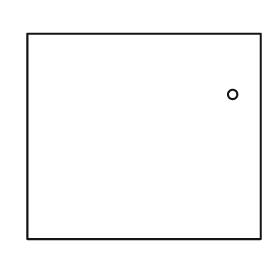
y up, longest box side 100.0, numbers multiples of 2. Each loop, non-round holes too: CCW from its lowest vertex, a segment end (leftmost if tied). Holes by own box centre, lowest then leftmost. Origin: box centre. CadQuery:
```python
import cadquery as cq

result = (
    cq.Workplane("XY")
    .moveTo(-50.0, -44.0)
    .lineTo(50.0, -44.0)
    .lineTo(50.0, 44.0)
    .lineTo(-50.0, 44.0)
    .close()
    .moveTo(38.0, 18.0)
    .circle(2.0)
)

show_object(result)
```